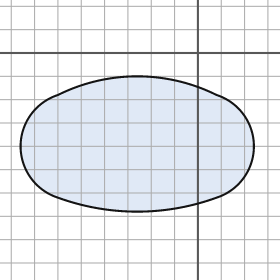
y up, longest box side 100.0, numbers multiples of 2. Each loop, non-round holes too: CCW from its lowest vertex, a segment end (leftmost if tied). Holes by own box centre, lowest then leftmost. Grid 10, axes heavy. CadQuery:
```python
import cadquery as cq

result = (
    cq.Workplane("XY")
    .moveTo(-60.0, -62.0)
    .threePointArc((-26.0, -68.0), (8.0, -62.0))
    .threePointArc((24.0, -40.0), (8.0, -18.0))
    .threePointArc((-26.0, -10.0), (-60.0, -18.0))
    .threePointArc((-76.0, -40.0), (-60.0, -62.0))
    .close()
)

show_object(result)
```